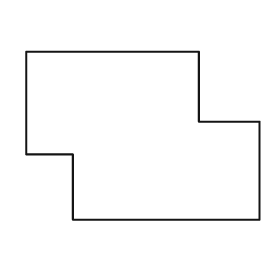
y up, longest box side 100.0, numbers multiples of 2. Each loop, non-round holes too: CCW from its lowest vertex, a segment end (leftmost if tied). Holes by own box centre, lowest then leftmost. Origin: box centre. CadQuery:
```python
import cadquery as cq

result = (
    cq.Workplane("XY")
    .moveTo(-30.0, -36.0)
    .lineTo(50.0, -36.0)
    .lineTo(50.0, 6.0)
    .lineTo(24.0, 6.0)
    .lineTo(24.0, 36.0)
    .lineTo(-50.0, 36.0)
    .lineTo(-50.0, -8.0)
    .lineTo(-30.0, -8.0)
    .close()
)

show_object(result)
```